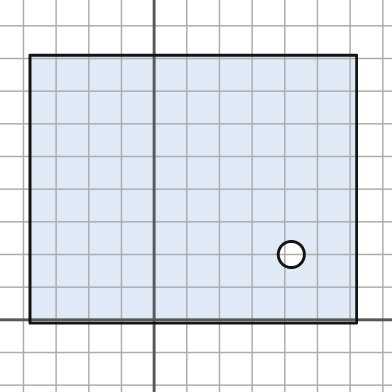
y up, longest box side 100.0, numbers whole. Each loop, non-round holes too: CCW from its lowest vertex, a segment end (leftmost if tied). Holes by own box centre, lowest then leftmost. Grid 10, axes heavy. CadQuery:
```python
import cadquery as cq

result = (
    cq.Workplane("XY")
    .moveTo(-38.0, -1.0)
    .lineTo(62.0, -1.0)
    .lineTo(62.0, 81.0)
    .lineTo(-38.0, 81.0)
    .close()
    .moveTo(42.0, 20.0)
    .circle(4.0)
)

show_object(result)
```